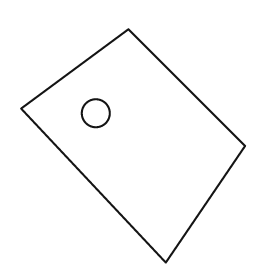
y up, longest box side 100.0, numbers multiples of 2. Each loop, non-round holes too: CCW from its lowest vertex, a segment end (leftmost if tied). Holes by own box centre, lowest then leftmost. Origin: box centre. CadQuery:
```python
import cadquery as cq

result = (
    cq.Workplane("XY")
    .moveTo(14.0, -50.0)
    .lineTo(48.0, 0.0)
    .lineTo(-2.0, 50.0)
    .lineTo(-48.0, 16.0)
    .close()
    .moveTo(-16.0, 14.0)
    .circle(6.0)
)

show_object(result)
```